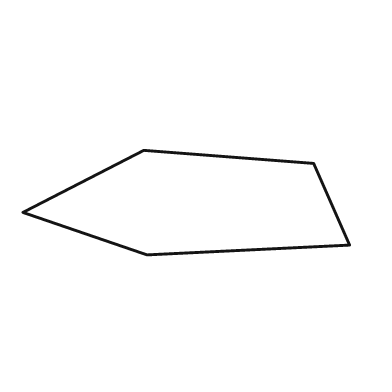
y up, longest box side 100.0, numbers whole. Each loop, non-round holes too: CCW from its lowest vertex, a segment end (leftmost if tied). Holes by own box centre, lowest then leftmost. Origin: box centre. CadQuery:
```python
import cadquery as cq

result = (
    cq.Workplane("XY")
    .moveTo(-12.0, -16.0)
    .lineTo(50.0, -13.0)
    .lineTo(39.0, 12.0)
    .lineTo(-13.0, 16.0)
    .lineTo(-50.0, -3.0)
    .close()
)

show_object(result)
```